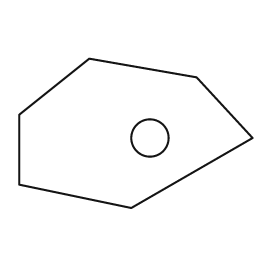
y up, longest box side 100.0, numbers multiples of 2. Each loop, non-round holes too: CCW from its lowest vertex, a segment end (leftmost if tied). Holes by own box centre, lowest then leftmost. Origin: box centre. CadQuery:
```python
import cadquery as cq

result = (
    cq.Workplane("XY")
    .moveTo(-2.0, -32.0)
    .lineTo(50.0, -2.0)
    .lineTo(26.0, 24.0)
    .lineTo(-20.0, 32.0)
    .lineTo(-50.0, 8.0)
    .lineTo(-50.0, -22.0)
    .close()
    .moveTo(6.0, -2.0)
    .circle(8.0)
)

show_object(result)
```